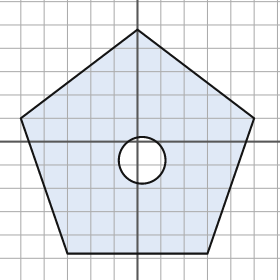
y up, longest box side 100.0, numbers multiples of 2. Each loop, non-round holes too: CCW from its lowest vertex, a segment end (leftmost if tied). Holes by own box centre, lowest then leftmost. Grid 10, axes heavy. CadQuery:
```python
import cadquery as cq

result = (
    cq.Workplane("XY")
    .moveTo(-30.0, -48.0)
    .lineTo(30.0, -48.0)
    .lineTo(50.0, 10.0)
    .lineTo(0.0, 48.0)
    .lineTo(-50.0, 10.0)
    .close()
    .moveTo(2.0, -8.0)
    .circle(10.0)
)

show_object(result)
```